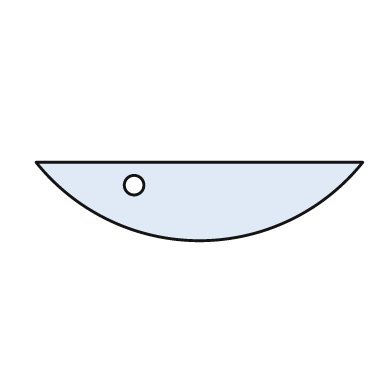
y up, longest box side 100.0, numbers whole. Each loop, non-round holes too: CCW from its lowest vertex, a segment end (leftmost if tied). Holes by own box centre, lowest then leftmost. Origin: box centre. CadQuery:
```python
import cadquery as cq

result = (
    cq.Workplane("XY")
    .moveTo(-50.0, 12.0)
    .threePointArc((0.0, -12.0), (50.0, 12.0))
    .close()
    .moveTo(-20.0, 5.0)
    .circle(3.0)
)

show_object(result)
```